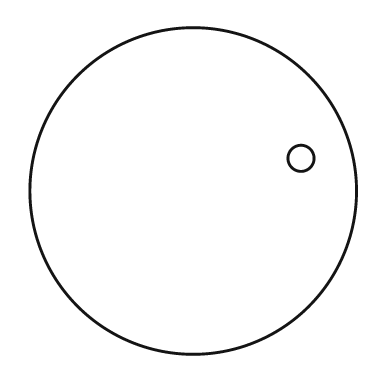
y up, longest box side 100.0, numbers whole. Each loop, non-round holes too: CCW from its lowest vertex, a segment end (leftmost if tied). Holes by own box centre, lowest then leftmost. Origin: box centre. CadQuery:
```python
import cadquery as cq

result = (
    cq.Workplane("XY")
    .moveTo(0.0, 0.0)
    .circle(50.0)
    .moveTo(33.0, 10.0)
    .circle(4.0)
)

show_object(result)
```